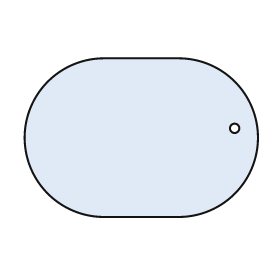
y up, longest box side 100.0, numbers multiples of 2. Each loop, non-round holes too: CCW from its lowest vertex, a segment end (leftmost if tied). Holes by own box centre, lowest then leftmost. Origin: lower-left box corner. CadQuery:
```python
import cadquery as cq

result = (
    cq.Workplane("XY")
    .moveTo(34.0, 0.0)
    .lineTo(66.0, 0.0)
    .threePointArc((100.0, 34.0), (66.0, 68.0))
    .lineTo(34.0, 68.0)
    .threePointArc((0.0, 34.0), (34.0, 0.0))
    .close()
    .moveTo(90.0, 38.0)
    .circle(2.0)
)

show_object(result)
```